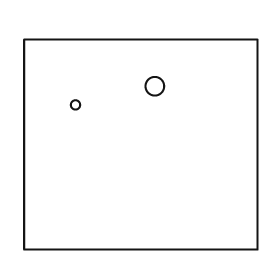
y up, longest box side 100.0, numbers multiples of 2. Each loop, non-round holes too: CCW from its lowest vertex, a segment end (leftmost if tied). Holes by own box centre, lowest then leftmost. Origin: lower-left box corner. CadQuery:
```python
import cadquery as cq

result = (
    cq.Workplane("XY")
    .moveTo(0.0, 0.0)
    .lineTo(100.0, 0.0)
    .lineTo(100.0, 90.0)
    .lineTo(0.0, 90.0)
    .close()
    .moveTo(22.0, 62.0)
    .circle(2.0)
    .moveTo(56.0, 70.0)
    .circle(4.0)
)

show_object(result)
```